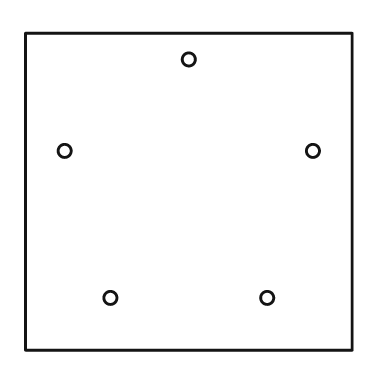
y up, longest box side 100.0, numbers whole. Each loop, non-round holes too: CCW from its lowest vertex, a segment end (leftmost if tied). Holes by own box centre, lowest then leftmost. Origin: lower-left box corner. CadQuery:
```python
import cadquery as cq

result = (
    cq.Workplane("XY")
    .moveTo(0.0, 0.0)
    .lineTo(100.0, 0.0)
    .lineTo(100.0, 97.0)
    .lineTo(0.0, 97.0)
    .close()
    .moveTo(26.0, 16.0)
    .circle(2.0)
    .moveTo(74.0, 16.0)
    .circle(2.0)
    .moveTo(12.0, 61.0)
    .circle(2.0)
    .moveTo(88.0, 61.0)
    .circle(2.0)
    .moveTo(50.0, 89.0)
    .circle(2.0)
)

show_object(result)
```